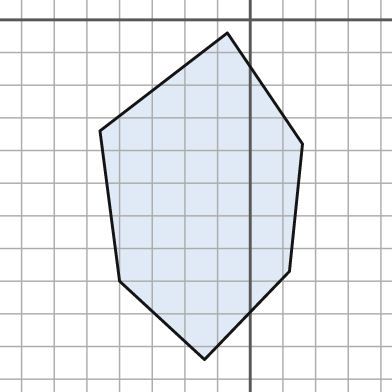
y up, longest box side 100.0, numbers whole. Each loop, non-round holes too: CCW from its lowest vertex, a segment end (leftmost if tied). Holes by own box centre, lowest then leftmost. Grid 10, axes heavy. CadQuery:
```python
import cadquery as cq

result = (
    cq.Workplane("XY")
    .moveTo(-14.0, -104.0)
    .lineTo(12.0, -77.0)
    .lineTo(16.0, -38.0)
    .lineTo(-7.0, -4.0)
    .lineTo(-46.0, -34.0)
    .lineTo(-40.0, -80.0)
    .close()
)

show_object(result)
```